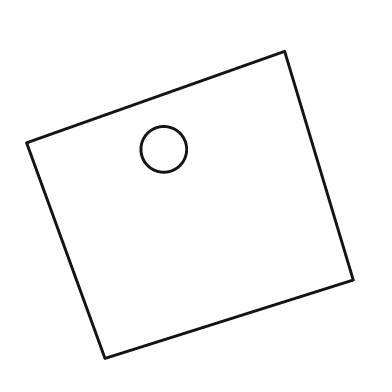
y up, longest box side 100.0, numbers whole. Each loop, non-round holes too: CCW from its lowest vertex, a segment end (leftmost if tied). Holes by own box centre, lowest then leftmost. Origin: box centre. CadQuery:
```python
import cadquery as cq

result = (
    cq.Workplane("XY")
    .moveTo(-26.0, -47.0)
    .lineTo(50.0, -23.0)
    .lineTo(29.0, 47.0)
    .lineTo(-50.0, 19.0)
    .close()
    .moveTo(-8.0, 17.0)
    .circle(7.0)
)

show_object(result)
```